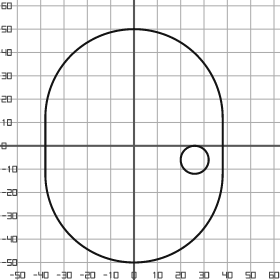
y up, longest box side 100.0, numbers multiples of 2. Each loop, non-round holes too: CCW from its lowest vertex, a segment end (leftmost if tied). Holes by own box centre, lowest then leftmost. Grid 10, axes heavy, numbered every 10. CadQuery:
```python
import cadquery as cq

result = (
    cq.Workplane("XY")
    .moveTo(-38.0, -12.0)
    .threePointArc((0.0, -50.0), (38.0, -12.0))
    .lineTo(38.0, 12.0)
    .threePointArc((0.0, 50.0), (-38.0, 12.0))
    .close()
    .moveTo(26.0, -6.0)
    .circle(6.0)
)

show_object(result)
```